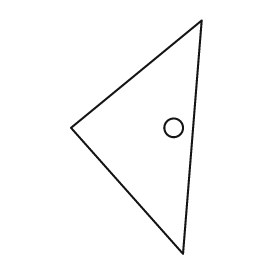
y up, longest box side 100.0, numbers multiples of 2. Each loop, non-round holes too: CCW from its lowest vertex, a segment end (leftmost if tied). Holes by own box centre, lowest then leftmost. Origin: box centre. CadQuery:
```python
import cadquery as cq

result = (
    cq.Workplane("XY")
    .moveTo(20.0, -50.0)
    .lineTo(28.0, 50.0)
    .lineTo(-28.0, 4.0)
    .close()
    .moveTo(16.0, 4.0)
    .circle(4.0)
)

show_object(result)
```